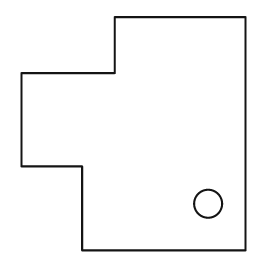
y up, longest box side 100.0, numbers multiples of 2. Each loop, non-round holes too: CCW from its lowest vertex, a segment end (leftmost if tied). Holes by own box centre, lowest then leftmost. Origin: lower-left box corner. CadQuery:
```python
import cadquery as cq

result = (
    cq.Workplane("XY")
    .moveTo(26.0, 0.0)
    .lineTo(96.0, 0.0)
    .lineTo(96.0, 100.0)
    .lineTo(40.0, 100.0)
    .lineTo(40.0, 76.0)
    .lineTo(0.0, 76.0)
    .lineTo(0.0, 36.0)
    .lineTo(26.0, 36.0)
    .close()
    .moveTo(80.0, 20.0)
    .circle(6.0)
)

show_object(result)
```